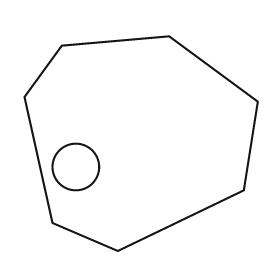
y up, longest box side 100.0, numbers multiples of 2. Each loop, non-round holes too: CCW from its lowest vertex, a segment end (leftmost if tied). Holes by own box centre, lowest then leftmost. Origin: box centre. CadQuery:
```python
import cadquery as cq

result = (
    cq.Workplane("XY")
    .moveTo(-10.0, -46.0)
    .lineTo(44.0, -20.0)
    .lineTo(50.0, 18.0)
    .lineTo(12.0, 46.0)
    .lineTo(-34.0, 42.0)
    .lineTo(-50.0, 20.0)
    .lineTo(-38.0, -34.0)
    .close()
    .moveTo(-28.0, -10.0)
    .circle(10.0)
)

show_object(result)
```